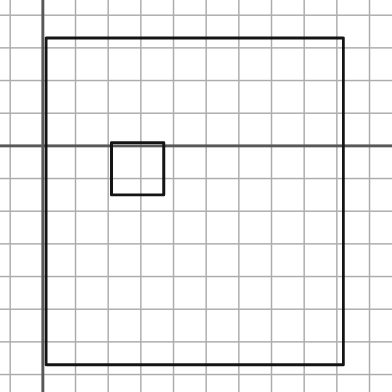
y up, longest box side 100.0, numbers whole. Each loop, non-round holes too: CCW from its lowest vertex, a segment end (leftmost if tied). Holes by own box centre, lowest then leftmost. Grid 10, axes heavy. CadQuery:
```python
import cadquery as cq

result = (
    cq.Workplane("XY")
    .moveTo(1.0, -67.0)
    .lineTo(92.0, -67.0)
    .lineTo(92.0, 33.0)
    .lineTo(1.0, 33.0)
    .close()
    .moveTo(21.0, -15.0)
    .lineTo(37.0, -15.0)
    .lineTo(37.0, 1.0)
    .lineTo(21.0, 1.0)
    .close()
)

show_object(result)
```